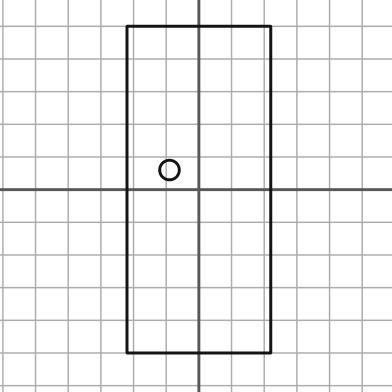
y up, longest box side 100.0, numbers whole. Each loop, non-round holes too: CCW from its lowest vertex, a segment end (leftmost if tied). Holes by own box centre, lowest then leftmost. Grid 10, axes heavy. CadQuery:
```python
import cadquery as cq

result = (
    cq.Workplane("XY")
    .moveTo(-22.0, -50.0)
    .lineTo(22.0, -50.0)
    .lineTo(22.0, 50.0)
    .lineTo(-22.0, 50.0)
    .close()
    .moveTo(-9.0, 6.0)
    .circle(3.0)
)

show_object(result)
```